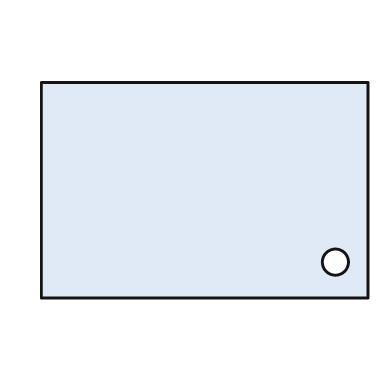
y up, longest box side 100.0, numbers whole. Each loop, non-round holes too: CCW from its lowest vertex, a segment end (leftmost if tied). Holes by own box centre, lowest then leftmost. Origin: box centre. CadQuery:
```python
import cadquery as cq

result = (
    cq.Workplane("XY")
    .moveTo(-50.0, -33.0)
    .lineTo(50.0, -33.0)
    .lineTo(50.0, 33.0)
    .lineTo(-50.0, 33.0)
    .close()
    .moveTo(40.0, -22.0)
    .circle(4.0)
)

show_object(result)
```